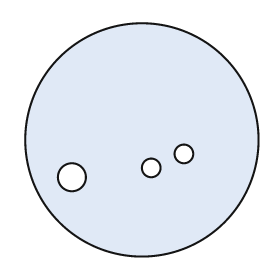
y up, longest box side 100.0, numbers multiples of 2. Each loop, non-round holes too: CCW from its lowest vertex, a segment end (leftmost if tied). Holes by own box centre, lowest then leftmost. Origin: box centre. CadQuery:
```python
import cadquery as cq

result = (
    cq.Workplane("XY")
    .moveTo(0.0, 0.0)
    .circle(50.0)
    .moveTo(-30.0, -16.0)
    .circle(6.0)
    .moveTo(4.0, -12.0)
    .circle(4.0)
    .moveTo(18.0, -6.0)
    .circle(4.0)
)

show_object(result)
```